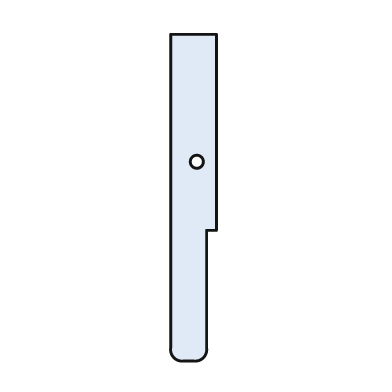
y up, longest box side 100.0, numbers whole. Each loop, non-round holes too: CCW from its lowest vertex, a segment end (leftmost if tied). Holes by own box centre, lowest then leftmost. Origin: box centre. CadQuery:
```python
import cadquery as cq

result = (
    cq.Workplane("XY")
    .moveTo(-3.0, -50.0)
    .lineTo(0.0, -50.0)
    .threePointArc((3.0, -49.0), (4.0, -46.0))
    .lineTo(4.0, -10.0)
    .lineTo(7.0, -10.0)
    .lineTo(7.0, 50.0)
    .lineTo(-7.0, 50.0)
    .lineTo(-7.0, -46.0)
    .threePointArc((-6.0, -49.0), (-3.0, -50.0))
    .close()
    .moveTo(1.0, 11.0)
    .circle(2.0)
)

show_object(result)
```